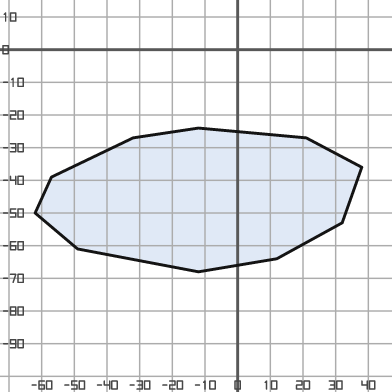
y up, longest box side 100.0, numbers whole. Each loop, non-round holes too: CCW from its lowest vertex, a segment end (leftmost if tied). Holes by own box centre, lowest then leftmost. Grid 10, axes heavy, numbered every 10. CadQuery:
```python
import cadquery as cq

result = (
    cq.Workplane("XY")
    .moveTo(-12.0, -68.0)
    .lineTo(12.0, -64.0)
    .lineTo(32.0, -53.0)
    .lineTo(38.0, -36.0)
    .lineTo(21.0, -27.0)
    .lineTo(-12.0, -24.0)
    .lineTo(-32.0, -27.0)
    .lineTo(-57.0, -39.0)
    .lineTo(-62.0, -50.0)
    .lineTo(-49.0, -61.0)
    .close()
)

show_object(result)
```